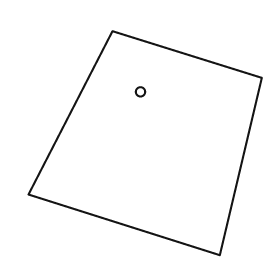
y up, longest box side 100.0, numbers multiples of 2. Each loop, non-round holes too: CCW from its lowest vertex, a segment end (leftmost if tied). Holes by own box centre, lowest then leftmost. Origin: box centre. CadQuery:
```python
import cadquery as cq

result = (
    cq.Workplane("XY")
    .moveTo(32.0, -48.0)
    .lineTo(50.0, 28.0)
    .lineTo(-14.0, 48.0)
    .lineTo(-50.0, -22.0)
    .close()
    .moveTo(-2.0, 22.0)
    .circle(2.0)
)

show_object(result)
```